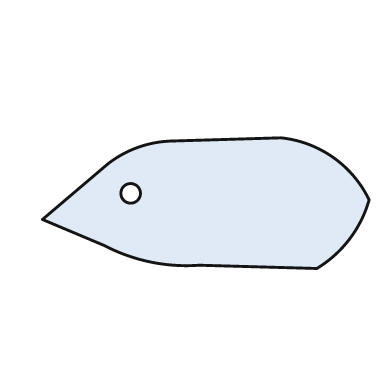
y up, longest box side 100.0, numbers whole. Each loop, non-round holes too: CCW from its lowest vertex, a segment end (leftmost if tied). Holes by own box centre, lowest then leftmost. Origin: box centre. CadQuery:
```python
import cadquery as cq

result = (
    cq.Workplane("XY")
    .moveTo(34.0, -20.0)
    .threePointArc((44.0, -11.0), (50.0, 1.0))
    .threePointArc((39.0, 14.0), (23.0, 20.0))
    .lineTo(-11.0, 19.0)
    .threePointArc((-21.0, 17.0), (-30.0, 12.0))
    .lineTo(-50.0, -5.0)
    .lineTo(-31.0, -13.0)
    .threePointArc((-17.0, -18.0), (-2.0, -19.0))
    .close()
    .moveTo(-23.0, 3.0)
    .circle(3.0)
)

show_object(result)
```